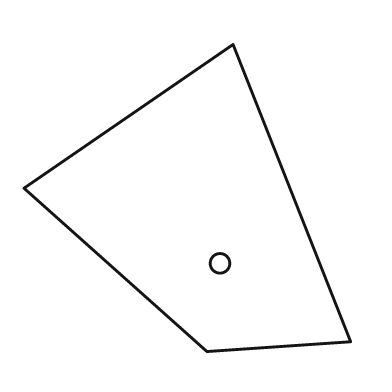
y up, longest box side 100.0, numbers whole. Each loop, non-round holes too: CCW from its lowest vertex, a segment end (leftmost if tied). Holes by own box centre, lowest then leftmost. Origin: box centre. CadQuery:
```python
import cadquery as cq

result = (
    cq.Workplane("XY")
    .moveTo(6.0, -47.0)
    .lineTo(50.0, -44.0)
    .lineTo(14.0, 47.0)
    .lineTo(-50.0, 3.0)
    .close()
    .moveTo(10.0, -20.0)
    .circle(3.0)
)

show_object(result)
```